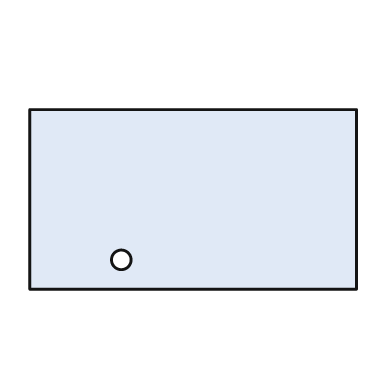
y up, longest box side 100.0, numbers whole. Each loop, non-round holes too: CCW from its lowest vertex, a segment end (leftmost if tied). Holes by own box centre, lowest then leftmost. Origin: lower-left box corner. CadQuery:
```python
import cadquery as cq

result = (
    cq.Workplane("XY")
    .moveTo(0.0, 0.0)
    .lineTo(100.0, 0.0)
    .lineTo(100.0, 55.0)
    .lineTo(0.0, 55.0)
    .close()
    .moveTo(28.0, 9.0)
    .circle(3.0)
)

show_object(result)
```